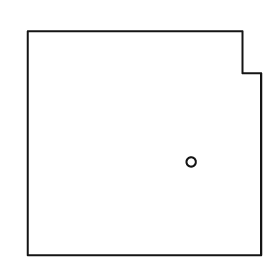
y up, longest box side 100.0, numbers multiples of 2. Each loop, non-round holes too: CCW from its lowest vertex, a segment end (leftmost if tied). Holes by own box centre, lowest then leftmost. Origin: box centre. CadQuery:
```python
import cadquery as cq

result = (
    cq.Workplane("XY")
    .moveTo(-50.0, -48.0)
    .lineTo(50.0, -48.0)
    .lineTo(50.0, 30.0)
    .lineTo(42.0, 30.0)
    .lineTo(42.0, 48.0)
    .lineTo(-50.0, 48.0)
    .close()
    .moveTo(20.0, -8.0)
    .circle(2.0)
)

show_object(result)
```